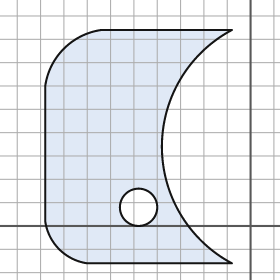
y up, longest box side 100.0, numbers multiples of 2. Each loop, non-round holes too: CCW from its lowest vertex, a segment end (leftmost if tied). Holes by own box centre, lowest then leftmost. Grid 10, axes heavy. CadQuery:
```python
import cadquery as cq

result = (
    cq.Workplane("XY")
    .moveTo(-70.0, -16.0)
    .lineTo(-8.0, -16.0)
    .threePointArc((-38.0, 34.0), (-8.0, 84.0))
    .lineTo(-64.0, 84.0)
    .threePointArc((-80.0, 76.0), (-88.0, 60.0))
    .lineTo(-88.0, 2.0)
    .threePointArc((-82.0, -10.0), (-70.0, -16.0))
    .close()
    .moveTo(-48.0, 8.0)
    .circle(8.0)
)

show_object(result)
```